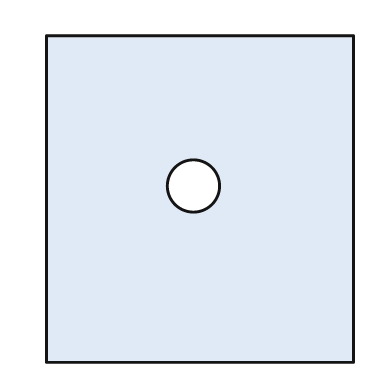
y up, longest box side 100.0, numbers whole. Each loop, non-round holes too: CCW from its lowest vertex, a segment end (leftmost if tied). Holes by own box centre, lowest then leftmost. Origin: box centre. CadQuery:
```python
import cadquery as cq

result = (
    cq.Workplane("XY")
    .moveTo(-47.0, -50.0)
    .lineTo(47.0, -50.0)
    .lineTo(47.0, 50.0)
    .lineTo(-47.0, 50.0)
    .close()
    .moveTo(-2.0, 4.0)
    .circle(8.0)
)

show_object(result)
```